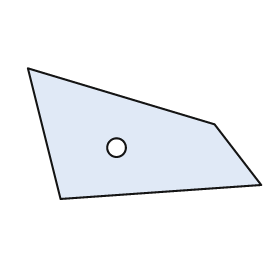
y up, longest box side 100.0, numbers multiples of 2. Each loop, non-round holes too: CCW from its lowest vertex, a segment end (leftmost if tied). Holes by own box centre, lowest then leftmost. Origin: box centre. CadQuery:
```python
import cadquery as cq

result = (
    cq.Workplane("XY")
    .moveTo(-36.0, -28.0)
    .lineTo(50.0, -22.0)
    .lineTo(30.0, 4.0)
    .lineTo(-50.0, 28.0)
    .close()
    .moveTo(-12.0, -6.0)
    .circle(4.0)
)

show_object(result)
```